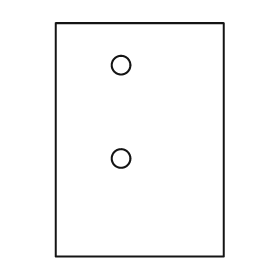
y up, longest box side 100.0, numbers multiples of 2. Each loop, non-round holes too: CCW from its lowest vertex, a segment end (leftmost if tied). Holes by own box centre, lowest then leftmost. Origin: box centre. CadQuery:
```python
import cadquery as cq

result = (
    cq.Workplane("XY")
    .moveTo(-36.0, -50.0)
    .lineTo(36.0, -50.0)
    .lineTo(36.0, 50.0)
    .lineTo(-36.0, 50.0)
    .close()
    .moveTo(-8.0, -8.0)
    .circle(4.0)
    .moveTo(-8.0, 32.0)
    .circle(4.0)
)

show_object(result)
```